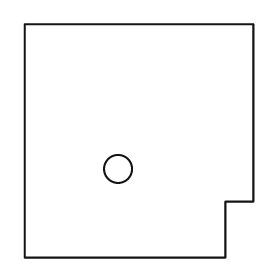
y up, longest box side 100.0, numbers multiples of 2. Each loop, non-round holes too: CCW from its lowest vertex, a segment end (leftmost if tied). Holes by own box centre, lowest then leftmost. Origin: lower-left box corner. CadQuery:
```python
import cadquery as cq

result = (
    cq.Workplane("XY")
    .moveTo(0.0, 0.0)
    .lineTo(86.0, 0.0)
    .lineTo(86.0, 24.0)
    .lineTo(98.0, 24.0)
    .lineTo(98.0, 100.0)
    .lineTo(0.0, 100.0)
    .close()
    .moveTo(40.0, 38.0)
    .circle(6.0)
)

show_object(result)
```